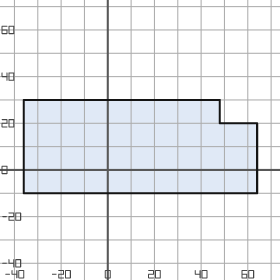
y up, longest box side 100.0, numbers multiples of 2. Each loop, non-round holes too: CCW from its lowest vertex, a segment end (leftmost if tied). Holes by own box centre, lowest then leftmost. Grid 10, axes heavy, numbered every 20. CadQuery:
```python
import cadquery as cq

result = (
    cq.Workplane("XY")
    .moveTo(-36.0, -10.0)
    .lineTo(64.0, -10.0)
    .lineTo(64.0, 20.0)
    .lineTo(48.0, 20.0)
    .lineTo(48.0, 30.0)
    .lineTo(-36.0, 30.0)
    .close()
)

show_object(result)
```